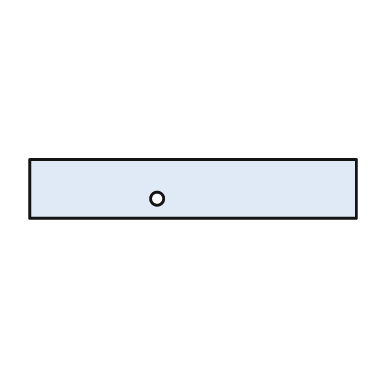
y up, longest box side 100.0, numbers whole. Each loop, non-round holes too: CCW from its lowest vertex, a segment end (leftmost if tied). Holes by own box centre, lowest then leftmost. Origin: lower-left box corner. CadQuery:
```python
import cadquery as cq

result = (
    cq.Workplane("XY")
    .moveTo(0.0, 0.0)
    .lineTo(100.0, 0.0)
    .lineTo(100.0, 18.0)
    .lineTo(0.0, 18.0)
    .close()
    .moveTo(39.0, 6.0)
    .circle(2.0)
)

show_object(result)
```